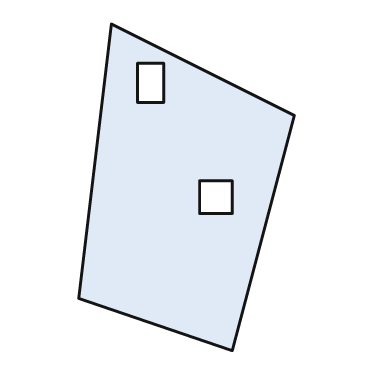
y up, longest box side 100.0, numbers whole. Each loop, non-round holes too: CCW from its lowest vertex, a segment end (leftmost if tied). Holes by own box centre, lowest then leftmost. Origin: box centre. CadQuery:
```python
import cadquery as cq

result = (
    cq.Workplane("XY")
    .moveTo(14.0, -50.0)
    .lineTo(33.0, 22.0)
    .lineTo(-23.0, 50.0)
    .lineTo(-33.0, -34.0)
    .close()
    .moveTo(4.0, -8.0)
    .lineTo(14.0, -8.0)
    .lineTo(14.0, 2.0)
    .lineTo(4.0, 2.0)
    .close()
    .moveTo(-15.0, 26.0)
    .lineTo(-7.0, 26.0)
    .lineTo(-7.0, 38.0)
    .lineTo(-15.0, 38.0)
    .close()
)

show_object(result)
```